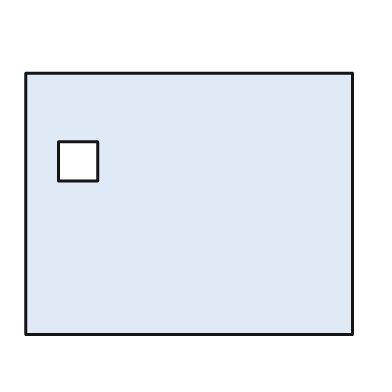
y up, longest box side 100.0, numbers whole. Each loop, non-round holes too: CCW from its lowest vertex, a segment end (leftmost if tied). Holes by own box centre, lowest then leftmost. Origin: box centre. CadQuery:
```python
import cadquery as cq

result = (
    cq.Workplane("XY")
    .moveTo(-50.0, -40.0)
    .lineTo(50.0, -40.0)
    .lineTo(50.0, 40.0)
    .lineTo(-50.0, 40.0)
    .close()
    .moveTo(-40.0, 7.0)
    .lineTo(-28.0, 7.0)
    .lineTo(-28.0, 19.0)
    .lineTo(-40.0, 19.0)
    .close()
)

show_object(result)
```